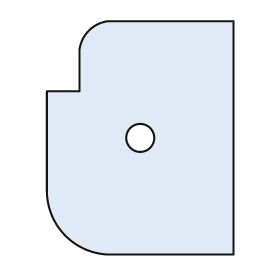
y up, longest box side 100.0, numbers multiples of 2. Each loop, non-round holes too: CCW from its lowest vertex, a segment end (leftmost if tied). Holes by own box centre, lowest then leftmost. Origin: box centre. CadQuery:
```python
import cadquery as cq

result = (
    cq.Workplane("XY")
    .moveTo(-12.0, -50.0)
    .lineTo(40.0, -50.0)
    .lineTo(40.0, 50.0)
    .lineTo(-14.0, 50.0)
    .threePointArc((-22.0, 46.0), (-26.0, 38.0))
    .lineTo(-26.0, 20.0)
    .lineTo(-40.0, 20.0)
    .lineTo(-40.0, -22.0)
    .threePointArc((-32.0, -42.0), (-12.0, -50.0))
    .close()
    .moveTo(0.0, 0.0)
    .circle(6.0)
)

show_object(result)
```